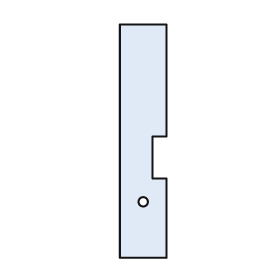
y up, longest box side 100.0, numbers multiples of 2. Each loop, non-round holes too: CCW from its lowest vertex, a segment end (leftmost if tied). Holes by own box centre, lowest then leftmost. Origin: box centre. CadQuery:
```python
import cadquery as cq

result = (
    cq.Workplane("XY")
    .moveTo(-10.0, -50.0)
    .lineTo(10.0, -50.0)
    .lineTo(10.0, -16.0)
    .lineTo(4.0, -16.0)
    .lineTo(4.0, 2.0)
    .lineTo(10.0, 2.0)
    .lineTo(10.0, 50.0)
    .lineTo(-10.0, 50.0)
    .close()
    .moveTo(0.0, -26.0)
    .circle(2.0)
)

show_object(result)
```